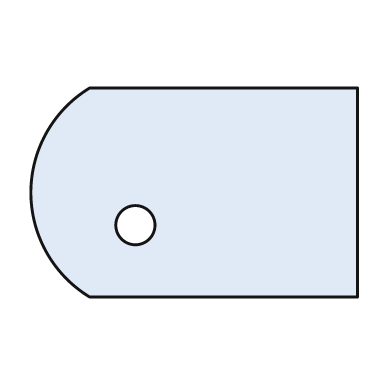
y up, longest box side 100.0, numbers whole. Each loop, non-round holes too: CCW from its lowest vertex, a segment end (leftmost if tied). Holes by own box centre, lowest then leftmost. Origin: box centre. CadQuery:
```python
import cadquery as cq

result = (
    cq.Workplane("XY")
    .moveTo(-32.0, -32.0)
    .lineTo(50.0, -32.0)
    .lineTo(50.0, 32.0)
    .lineTo(-32.0, 32.0)
    .threePointArc((-50.0, 0.0), (-32.0, -32.0))
    .close()
    .moveTo(-18.0, -10.0)
    .circle(6.0)
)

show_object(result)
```